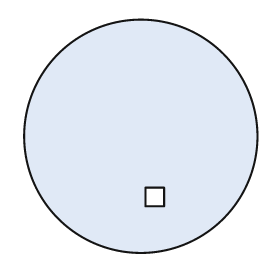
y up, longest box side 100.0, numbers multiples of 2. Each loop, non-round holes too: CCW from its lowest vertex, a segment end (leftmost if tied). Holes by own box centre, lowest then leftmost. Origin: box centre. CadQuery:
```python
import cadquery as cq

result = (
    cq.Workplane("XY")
    .moveTo(0.0, 0.0)
    .circle(50.0)
    .moveTo(2.0, -30.0)
    .lineTo(10.0, -30.0)
    .lineTo(10.0, -22.0)
    .lineTo(2.0, -22.0)
    .close()
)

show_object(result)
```